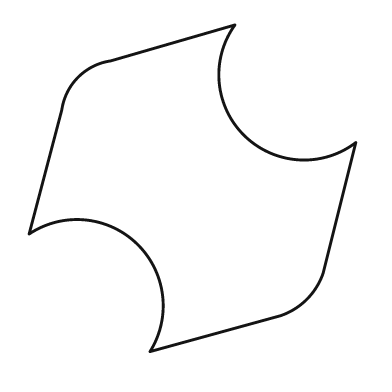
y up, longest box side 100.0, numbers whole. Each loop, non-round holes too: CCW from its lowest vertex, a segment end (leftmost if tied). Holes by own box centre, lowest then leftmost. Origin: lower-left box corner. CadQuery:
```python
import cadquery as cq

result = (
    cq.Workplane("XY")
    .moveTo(37.0, 0.0)
    .lineTo(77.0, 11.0)
    .threePointArc((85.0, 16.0), (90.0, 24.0))
    .lineTo(100.0, 64.0)
    .threePointArc((66.0, 66.0), (63.0, 100.0))
    .lineTo(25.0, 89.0)
    .threePointArc((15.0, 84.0), (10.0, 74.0))
    .lineTo(0.0, 36.0)
    .threePointArc((33.0, 33.0), (37.0, 0.0))
    .close()
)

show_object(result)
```